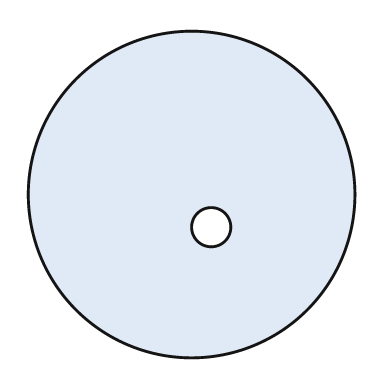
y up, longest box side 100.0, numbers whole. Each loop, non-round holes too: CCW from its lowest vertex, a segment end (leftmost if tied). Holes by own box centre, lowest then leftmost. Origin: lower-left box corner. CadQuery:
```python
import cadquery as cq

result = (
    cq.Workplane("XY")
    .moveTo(50.0, 50.0)
    .circle(50.0)
    .moveTo(56.0, 40.0)
    .circle(6.0)
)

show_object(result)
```